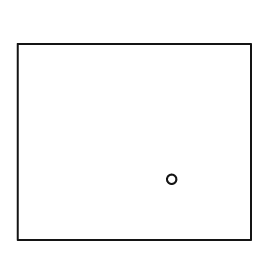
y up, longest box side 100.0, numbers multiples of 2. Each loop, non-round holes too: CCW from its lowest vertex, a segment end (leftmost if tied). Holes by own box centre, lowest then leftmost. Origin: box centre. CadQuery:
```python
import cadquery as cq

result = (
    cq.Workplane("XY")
    .moveTo(-50.0, -42.0)
    .lineTo(50.0, -42.0)
    .lineTo(50.0, 42.0)
    .lineTo(-50.0, 42.0)
    .close()
    .moveTo(16.0, -16.0)
    .circle(2.0)
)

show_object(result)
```